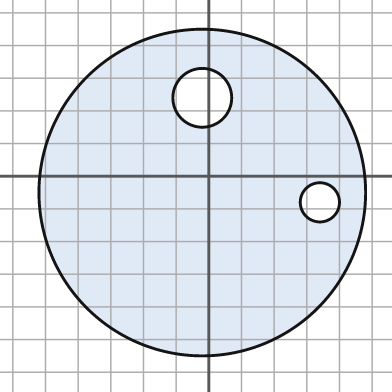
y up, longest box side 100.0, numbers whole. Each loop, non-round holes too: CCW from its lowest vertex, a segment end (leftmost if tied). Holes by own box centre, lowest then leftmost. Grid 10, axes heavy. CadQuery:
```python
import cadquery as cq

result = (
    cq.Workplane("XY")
    .moveTo(-2.0, -5.0)
    .circle(50.0)
    .moveTo(34.0, -8.0)
    .circle(6.0)
    .moveTo(-2.0, 24.0)
    .circle(9.0)
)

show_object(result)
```